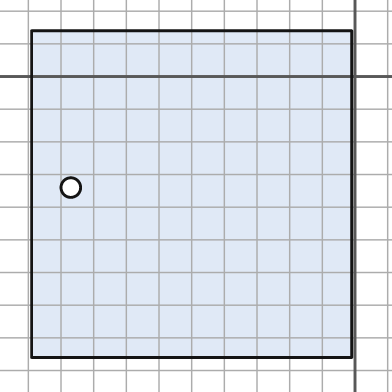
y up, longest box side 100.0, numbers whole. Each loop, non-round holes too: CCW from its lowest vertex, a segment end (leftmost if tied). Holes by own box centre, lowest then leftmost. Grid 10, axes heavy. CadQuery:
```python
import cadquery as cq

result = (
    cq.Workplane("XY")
    .moveTo(-99.0, -86.0)
    .lineTo(-1.0, -86.0)
    .lineTo(-1.0, 14.0)
    .lineTo(-99.0, 14.0)
    .close()
    .moveTo(-87.0, -34.0)
    .circle(3.0)
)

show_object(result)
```